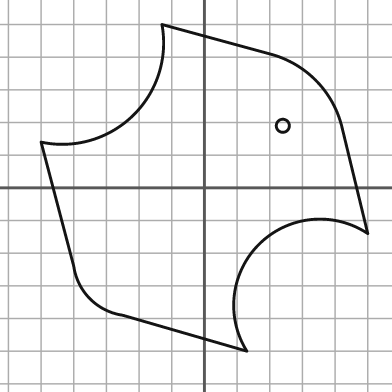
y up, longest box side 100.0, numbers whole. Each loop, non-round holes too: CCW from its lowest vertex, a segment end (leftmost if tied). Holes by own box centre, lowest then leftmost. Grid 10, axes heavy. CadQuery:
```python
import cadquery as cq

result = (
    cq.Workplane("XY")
    .moveTo(13.0, -50.0)
    .threePointArc((17.0, -17.0), (50.0, -14.0))
    .lineTo(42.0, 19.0)
    .threePointArc((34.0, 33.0), (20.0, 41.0))
    .lineTo(-13.0, 50.0)
    .threePointArc((-22.0, 22.0), (-50.0, 14.0))
    .lineTo(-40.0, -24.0)
    .threePointArc((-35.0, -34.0), (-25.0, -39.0))
    .close()
    .moveTo(24.0, 19.0)
    .circle(2.0)
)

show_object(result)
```